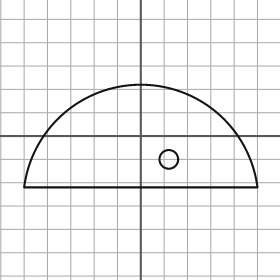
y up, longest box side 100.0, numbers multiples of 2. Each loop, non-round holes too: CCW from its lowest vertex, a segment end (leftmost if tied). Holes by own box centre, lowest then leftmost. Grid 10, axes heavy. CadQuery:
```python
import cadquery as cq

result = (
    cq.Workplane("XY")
    .moveTo(-50.0, -22.0)
    .lineTo(50.0, -22.0)
    .threePointArc((0.0, 22.0), (-50.0, -22.0))
    .close()
    .moveTo(12.0, -10.0)
    .circle(4.0)
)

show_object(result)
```